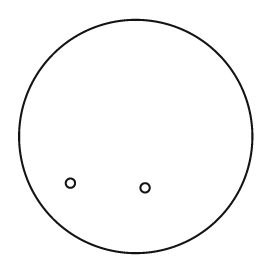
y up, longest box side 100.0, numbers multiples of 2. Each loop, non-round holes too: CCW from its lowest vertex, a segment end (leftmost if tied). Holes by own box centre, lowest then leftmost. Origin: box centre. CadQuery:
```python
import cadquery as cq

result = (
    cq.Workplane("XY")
    .moveTo(0.0, 0.0)
    .circle(50.0)
    .moveTo(4.0, -22.0)
    .circle(2.0)
    .moveTo(-28.0, -20.0)
    .circle(2.0)
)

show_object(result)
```